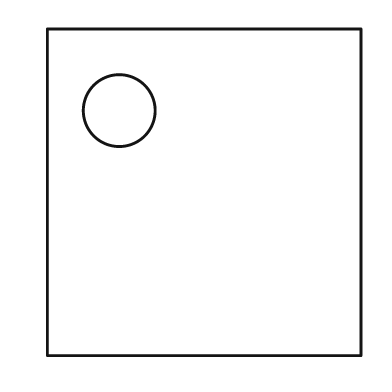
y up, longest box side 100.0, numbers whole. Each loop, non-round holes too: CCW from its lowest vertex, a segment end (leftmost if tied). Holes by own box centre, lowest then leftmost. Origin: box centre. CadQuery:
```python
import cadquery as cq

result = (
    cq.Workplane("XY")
    .moveTo(-48.0, -50.0)
    .lineTo(48.0, -50.0)
    .lineTo(48.0, 50.0)
    .lineTo(-48.0, 50.0)
    .close()
    .moveTo(-26.0, 25.0)
    .circle(11.0)
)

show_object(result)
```